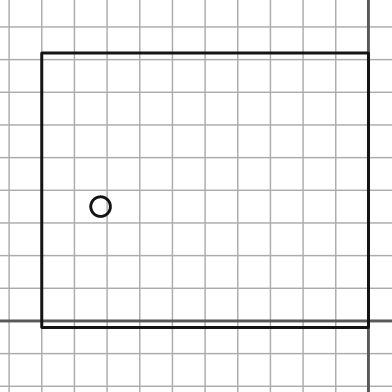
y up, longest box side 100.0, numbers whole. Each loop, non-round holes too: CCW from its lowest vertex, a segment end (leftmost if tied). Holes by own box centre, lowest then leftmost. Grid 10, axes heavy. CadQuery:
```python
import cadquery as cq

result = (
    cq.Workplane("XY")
    .moveTo(-100.0, -2.0)
    .lineTo(0.0, -2.0)
    .lineTo(0.0, 82.0)
    .lineTo(-100.0, 82.0)
    .close()
    .moveTo(-82.0, 35.0)
    .circle(3.0)
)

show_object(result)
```